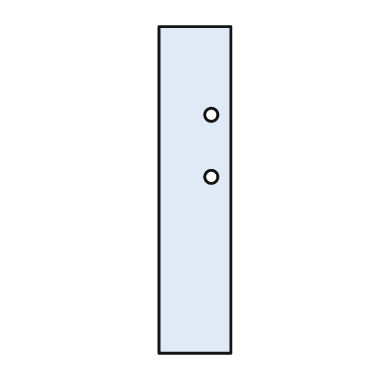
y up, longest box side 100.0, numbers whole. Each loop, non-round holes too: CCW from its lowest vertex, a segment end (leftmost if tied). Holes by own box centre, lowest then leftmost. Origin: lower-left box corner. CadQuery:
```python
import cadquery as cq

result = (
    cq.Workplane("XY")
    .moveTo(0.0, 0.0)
    .lineTo(22.0, 0.0)
    .lineTo(22.0, 100.0)
    .lineTo(0.0, 100.0)
    .close()
    .moveTo(16.0, 54.0)
    .circle(2.0)
    .moveTo(16.0, 73.0)
    .circle(2.0)
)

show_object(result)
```